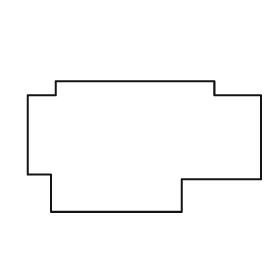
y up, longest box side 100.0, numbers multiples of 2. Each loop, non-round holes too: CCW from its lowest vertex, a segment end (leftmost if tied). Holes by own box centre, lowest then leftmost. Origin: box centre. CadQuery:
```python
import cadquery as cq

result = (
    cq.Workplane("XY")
    .moveTo(-40.0, -28.0)
    .lineTo(16.0, -28.0)
    .lineTo(16.0, -14.0)
    .lineTo(50.0, -14.0)
    .lineTo(50.0, 22.0)
    .lineTo(30.0, 22.0)
    .lineTo(30.0, 28.0)
    .lineTo(-38.0, 28.0)
    .lineTo(-38.0, 22.0)
    .lineTo(-50.0, 22.0)
    .lineTo(-50.0, -12.0)
    .lineTo(-40.0, -12.0)
    .close()
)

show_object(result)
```